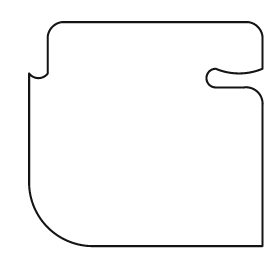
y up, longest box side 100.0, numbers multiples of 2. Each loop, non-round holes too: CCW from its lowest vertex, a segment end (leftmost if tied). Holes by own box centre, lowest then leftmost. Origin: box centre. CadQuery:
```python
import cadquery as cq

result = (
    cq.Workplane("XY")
    .moveTo(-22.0, -48.0)
    .lineTo(50.0, -48.0)
    .lineTo(50.0, 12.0)
    .threePointArc((48.0, 18.0), (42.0, 20.0))
    .lineTo(30.0, 20.0)
    .threePointArc((26.0, 24.0), (30.0, 28.0))
    .threePointArc((40.0, 26.0), (50.0, 28.0))
    .lineTo(50.0, 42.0)
    .threePointArc((48.0, 46.0), (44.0, 48.0))
    .lineTo(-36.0, 48.0)
    .threePointArc((-40.0, 46.0), (-42.0, 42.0))
    .lineTo(-42.0, 26.0)
    .threePointArc((-46.0, 24.0), (-50.0, 26.0))
    .lineTo(-50.0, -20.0)
    .threePointArc((-42.0, -40.0), (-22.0, -48.0))
    .close()
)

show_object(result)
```